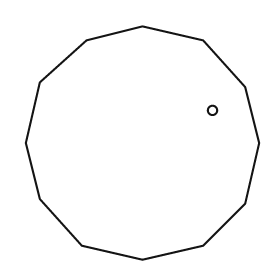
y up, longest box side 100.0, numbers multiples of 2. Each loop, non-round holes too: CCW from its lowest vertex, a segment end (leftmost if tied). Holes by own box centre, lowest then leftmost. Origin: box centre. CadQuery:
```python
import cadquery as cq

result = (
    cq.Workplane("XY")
    .moveTo(0.0, -50.0)
    .lineTo(26.0, -44.0)
    .lineTo(44.0, -26.0)
    .lineTo(50.0, 0.0)
    .lineTo(44.0, 24.0)
    .lineTo(26.0, 44.0)
    .lineTo(0.0, 50.0)
    .lineTo(-24.0, 44.0)
    .lineTo(-44.0, 26.0)
    .lineTo(-50.0, 0.0)
    .lineTo(-44.0, -24.0)
    .lineTo(-26.0, -44.0)
    .close()
    .moveTo(30.0, 14.0)
    .circle(2.0)
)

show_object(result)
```